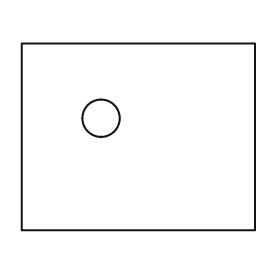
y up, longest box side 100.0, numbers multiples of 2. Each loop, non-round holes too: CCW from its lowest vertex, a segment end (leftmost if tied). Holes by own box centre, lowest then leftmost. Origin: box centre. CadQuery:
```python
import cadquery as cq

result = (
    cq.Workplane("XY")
    .moveTo(-50.0, -40.0)
    .lineTo(50.0, -40.0)
    .lineTo(50.0, 40.0)
    .lineTo(-50.0, 40.0)
    .close()
    .moveTo(-16.0, 8.0)
    .circle(8.0)
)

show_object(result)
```